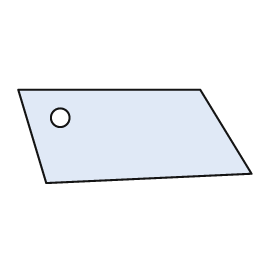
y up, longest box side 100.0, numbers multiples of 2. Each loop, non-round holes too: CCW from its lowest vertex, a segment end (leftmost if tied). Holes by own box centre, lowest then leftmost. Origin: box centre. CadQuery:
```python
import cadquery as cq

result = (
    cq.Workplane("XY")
    .moveTo(-38.0, -20.0)
    .lineTo(50.0, -16.0)
    .lineTo(28.0, 20.0)
    .lineTo(-50.0, 20.0)
    .close()
    .moveTo(-32.0, 8.0)
    .circle(4.0)
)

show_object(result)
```